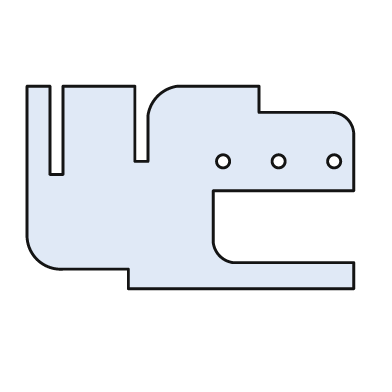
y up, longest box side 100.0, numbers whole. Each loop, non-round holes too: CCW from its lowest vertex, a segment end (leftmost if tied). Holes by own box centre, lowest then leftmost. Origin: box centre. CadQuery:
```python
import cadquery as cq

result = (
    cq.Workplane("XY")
    .moveTo(-19.0, -31.0)
    .lineTo(50.0, -31.0)
    .lineTo(50.0, -23.0)
    .lineTo(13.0, -23.0)
    .threePointArc((9.0, -21.0), (7.0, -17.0))
    .lineTo(7.0, -1.0)
    .lineTo(50.0, -1.0)
    .lineTo(50.0, 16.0)
    .threePointArc((48.0, 21.0), (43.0, 23.0))
    .lineTo(21.0, 23.0)
    .lineTo(21.0, 31.0)
    .lineTo(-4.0, 31.0)
    .threePointArc((-10.0, 28.0), (-13.0, 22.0))
    .lineTo(-13.0, 8.0)
    .lineTo(-17.0, 8.0)
    .lineTo(-17.0, 31.0)
    .lineTo(-39.0, 31.0)
    .lineTo(-39.0, 4.0)
    .lineTo(-43.0, 4.0)
    .lineTo(-43.0, 31.0)
    .lineTo(-50.0, 31.0)
    .lineTo(-50.0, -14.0)
    .threePointArc((-47.0, -22.0), (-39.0, -25.0))
    .lineTo(-19.0, -25.0)
    .close()
    .moveTo(10.0, 8.0)
    .circle(2.0)
    .moveTo(27.0, 8.0)
    .circle(2.0)
    .moveTo(44.0, 8.0)
    .circle(2.0)
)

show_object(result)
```